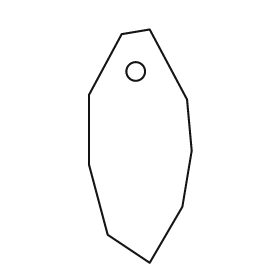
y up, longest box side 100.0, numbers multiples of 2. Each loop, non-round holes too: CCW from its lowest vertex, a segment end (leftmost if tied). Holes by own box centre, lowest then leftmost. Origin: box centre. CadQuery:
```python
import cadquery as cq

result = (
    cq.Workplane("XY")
    .moveTo(4.0, -50.0)
    .lineTo(18.0, -26.0)
    .lineTo(22.0, -2.0)
    .lineTo(20.0, 20.0)
    .lineTo(4.0, 50.0)
    .lineTo(-8.0, 48.0)
    .lineTo(-22.0, 22.0)
    .lineTo(-22.0, -8.0)
    .lineTo(-14.0, -38.0)
    .close()
    .moveTo(-2.0, 32.0)
    .circle(4.0)
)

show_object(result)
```